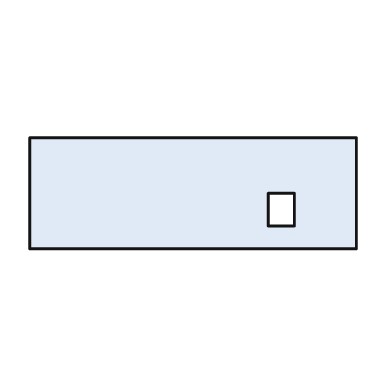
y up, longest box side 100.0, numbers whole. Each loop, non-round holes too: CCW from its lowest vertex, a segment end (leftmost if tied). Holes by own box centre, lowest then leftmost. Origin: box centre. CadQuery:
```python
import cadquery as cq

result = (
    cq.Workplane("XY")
    .moveTo(-50.0, -17.0)
    .lineTo(50.0, -17.0)
    .lineTo(50.0, 17.0)
    .lineTo(-50.0, 17.0)
    .close()
    .moveTo(23.0, -10.0)
    .lineTo(31.0, -10.0)
    .lineTo(31.0, 0.0)
    .lineTo(23.0, 0.0)
    .close()
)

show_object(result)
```